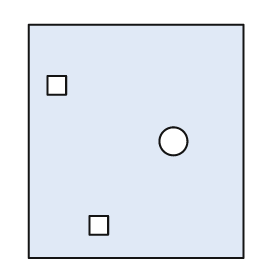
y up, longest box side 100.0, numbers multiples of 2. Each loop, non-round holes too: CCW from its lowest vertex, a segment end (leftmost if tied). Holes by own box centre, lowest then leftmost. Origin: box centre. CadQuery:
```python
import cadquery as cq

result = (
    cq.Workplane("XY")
    .moveTo(-46.0, -50.0)
    .lineTo(46.0, -50.0)
    .lineTo(46.0, 50.0)
    .lineTo(-46.0, 50.0)
    .close()
    .moveTo(-20.0, -40.0)
    .lineTo(-12.0, -40.0)
    .lineTo(-12.0, -32.0)
    .lineTo(-20.0, -32.0)
    .close()
    .moveTo(16.0, 0.0)
    .circle(6.0)
    .moveTo(-38.0, 20.0)
    .lineTo(-30.0, 20.0)
    .lineTo(-30.0, 28.0)
    .lineTo(-38.0, 28.0)
    .close()
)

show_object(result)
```